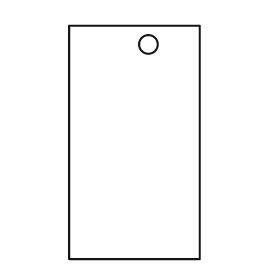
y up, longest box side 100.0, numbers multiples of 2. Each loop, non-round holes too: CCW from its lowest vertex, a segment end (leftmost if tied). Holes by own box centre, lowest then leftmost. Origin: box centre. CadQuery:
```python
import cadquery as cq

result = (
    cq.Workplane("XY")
    .moveTo(-28.0, -50.0)
    .lineTo(28.0, -50.0)
    .lineTo(28.0, 50.0)
    .lineTo(-28.0, 50.0)
    .close()
    .moveTo(6.0, 42.0)
    .circle(4.0)
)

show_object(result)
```